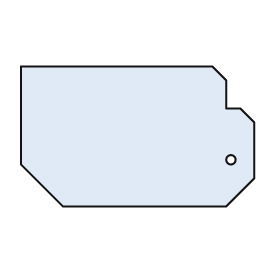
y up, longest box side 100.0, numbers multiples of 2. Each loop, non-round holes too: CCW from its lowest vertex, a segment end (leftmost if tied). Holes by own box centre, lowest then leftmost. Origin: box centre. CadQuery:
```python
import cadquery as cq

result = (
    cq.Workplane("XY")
    .moveTo(-32.0, -30.0)
    .lineTo(38.0, -30.0)
    .lineTo(50.0, -18.0)
    .lineTo(50.0, 6.0)
    .lineTo(44.0, 12.0)
    .lineTo(38.0, 12.0)
    .lineTo(38.0, 24.0)
    .lineTo(32.0, 30.0)
    .lineTo(-50.0, 30.0)
    .lineTo(-50.0, -12.0)
    .close()
    .moveTo(40.0, -10.0)
    .circle(2.0)
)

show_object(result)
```